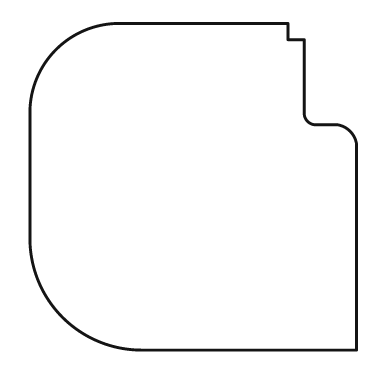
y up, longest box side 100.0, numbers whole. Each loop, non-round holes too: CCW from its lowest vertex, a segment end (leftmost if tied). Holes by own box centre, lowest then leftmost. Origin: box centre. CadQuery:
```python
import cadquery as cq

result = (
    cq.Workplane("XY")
    .moveTo(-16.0, -50.0)
    .lineTo(50.0, -50.0)
    .lineTo(50.0, 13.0)
    .threePointArc((48.0, 17.0), (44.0, 19.0))
    .lineTo(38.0, 19.0)
    .threePointArc((35.0, 20.0), (34.0, 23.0))
    .lineTo(34.0, 45.0)
    .lineTo(29.0, 45.0)
    .lineTo(29.0, 50.0)
    .lineTo(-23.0, 50.0)
    .threePointArc((-42.0, 42.0), (-50.0, 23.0))
    .lineTo(-50.0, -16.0)
    .threePointArc((-40.0, -40.0), (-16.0, -50.0))
    .close()
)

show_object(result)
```